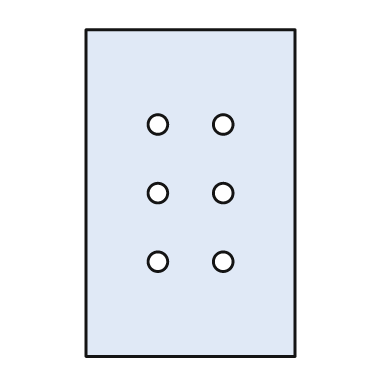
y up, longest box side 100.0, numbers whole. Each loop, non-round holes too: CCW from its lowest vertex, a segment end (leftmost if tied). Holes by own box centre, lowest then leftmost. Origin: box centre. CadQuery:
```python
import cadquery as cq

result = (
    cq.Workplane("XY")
    .moveTo(-32.0, -50.0)
    .lineTo(32.0, -50.0)
    .lineTo(32.0, 50.0)
    .lineTo(-32.0, 50.0)
    .close()
    .moveTo(-10.0, -21.0)
    .circle(3.0)
    .moveTo(10.0, -21.0)
    .circle(3.0)
    .moveTo(-10.0, 0.0)
    .circle(3.0)
    .moveTo(10.0, 0.0)
    .circle(3.0)
    .moveTo(-10.0, 21.0)
    .circle(3.0)
    .moveTo(10.0, 21.0)
    .circle(3.0)
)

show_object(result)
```